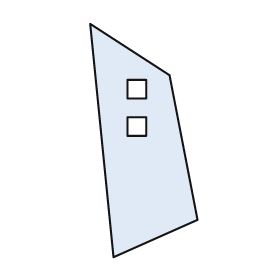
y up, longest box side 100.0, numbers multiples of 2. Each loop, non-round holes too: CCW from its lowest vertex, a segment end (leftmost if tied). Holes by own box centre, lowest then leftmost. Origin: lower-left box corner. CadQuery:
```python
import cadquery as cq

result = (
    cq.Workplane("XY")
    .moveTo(10.0, 0.0)
    .lineTo(46.0, 16.0)
    .lineTo(34.0, 78.0)
    .lineTo(0.0, 100.0)
    .close()
    .moveTo(16.0, 52.0)
    .lineTo(24.0, 52.0)
    .lineTo(24.0, 60.0)
    .lineTo(16.0, 60.0)
    .close()
    .moveTo(16.0, 68.0)
    .lineTo(24.0, 68.0)
    .lineTo(24.0, 76.0)
    .lineTo(16.0, 76.0)
    .close()
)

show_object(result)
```